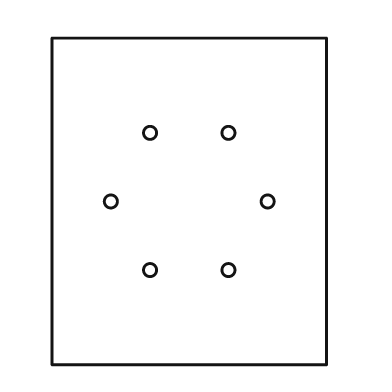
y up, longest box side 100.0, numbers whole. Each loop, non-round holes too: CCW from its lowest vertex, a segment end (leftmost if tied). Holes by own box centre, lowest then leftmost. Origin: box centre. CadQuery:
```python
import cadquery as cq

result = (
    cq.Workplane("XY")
    .moveTo(-42.0, -50.0)
    .lineTo(42.0, -50.0)
    .lineTo(42.0, 50.0)
    .lineTo(-42.0, 50.0)
    .close()
    .moveTo(-12.0, -21.0)
    .circle(2.0)
    .moveTo(12.0, -21.0)
    .circle(2.0)
    .moveTo(-24.0, 0.0)
    .circle(2.0)
    .moveTo(24.0, 0.0)
    .circle(2.0)
    .moveTo(-12.0, 21.0)
    .circle(2.0)
    .moveTo(12.0, 21.0)
    .circle(2.0)
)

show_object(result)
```